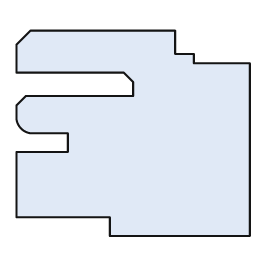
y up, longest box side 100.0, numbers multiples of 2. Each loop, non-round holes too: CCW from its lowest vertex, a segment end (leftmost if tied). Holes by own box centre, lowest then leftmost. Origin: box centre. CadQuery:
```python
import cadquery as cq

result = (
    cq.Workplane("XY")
    .moveTo(-10.0, -44.0)
    .lineTo(50.0, -44.0)
    .lineTo(50.0, 30.0)
    .lineTo(26.0, 30.0)
    .lineTo(26.0, 34.0)
    .lineTo(18.0, 34.0)
    .lineTo(18.0, 44.0)
    .lineTo(-44.0, 44.0)
    .lineTo(-50.0, 38.0)
    .lineTo(-50.0, 26.0)
    .lineTo(-4.0, 26.0)
    .lineTo(0.0, 22.0)
    .lineTo(0.0, 16.0)
    .lineTo(-46.0, 16.0)
    .lineTo(-50.0, 12.0)
    .lineTo(-50.0, 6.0)
    .threePointArc((-48.0, 2.0), (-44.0, 0.0))
    .lineTo(-28.0, 0.0)
    .lineTo(-28.0, -8.0)
    .lineTo(-50.0, -8.0)
    .lineTo(-50.0, -36.0)
    .lineTo(-10.0, -36.0)
    .close()
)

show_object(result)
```